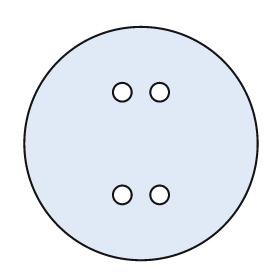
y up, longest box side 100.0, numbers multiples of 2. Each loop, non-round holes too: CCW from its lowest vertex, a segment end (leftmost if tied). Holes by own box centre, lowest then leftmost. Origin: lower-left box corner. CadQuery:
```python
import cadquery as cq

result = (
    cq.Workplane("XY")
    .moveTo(50.0, 50.0)
    .circle(50.0)
    .moveTo(42.0, 28.0)
    .circle(4.0)
    .moveTo(58.0, 28.0)
    .circle(4.0)
    .moveTo(42.0, 72.0)
    .circle(4.0)
    .moveTo(58.0, 72.0)
    .circle(4.0)
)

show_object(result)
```